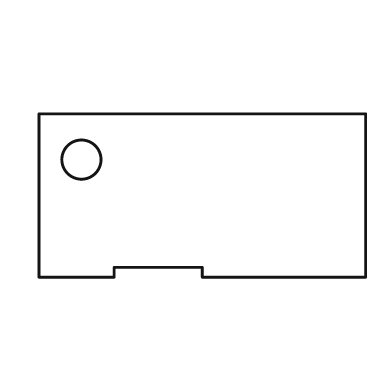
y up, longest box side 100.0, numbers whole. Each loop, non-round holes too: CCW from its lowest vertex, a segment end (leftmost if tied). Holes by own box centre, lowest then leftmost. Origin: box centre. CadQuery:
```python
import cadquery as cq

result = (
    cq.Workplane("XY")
    .moveTo(-50.0, -25.0)
    .lineTo(-27.0, -25.0)
    .lineTo(-27.0, -22.0)
    .lineTo(0.0, -22.0)
    .lineTo(0.0, -25.0)
    .lineTo(50.0, -25.0)
    .lineTo(50.0, 25.0)
    .lineTo(-50.0, 25.0)
    .close()
    .moveTo(-37.0, 11.0)
    .circle(6.0)
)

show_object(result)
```